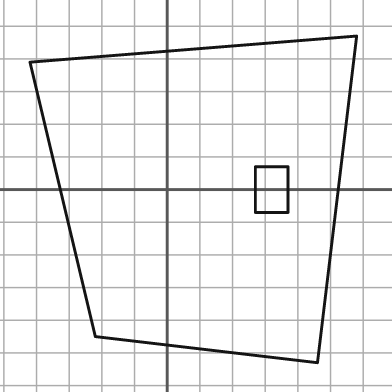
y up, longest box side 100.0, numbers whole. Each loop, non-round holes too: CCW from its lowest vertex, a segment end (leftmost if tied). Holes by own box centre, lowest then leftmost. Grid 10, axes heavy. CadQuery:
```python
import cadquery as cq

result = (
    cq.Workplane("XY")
    .moveTo(46.0, -53.0)
    .lineTo(58.0, 47.0)
    .lineTo(-42.0, 39.0)
    .lineTo(-22.0, -45.0)
    .close()
    .moveTo(27.0, -7.0)
    .lineTo(37.0, -7.0)
    .lineTo(37.0, 7.0)
    .lineTo(27.0, 7.0)
    .close()
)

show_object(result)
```